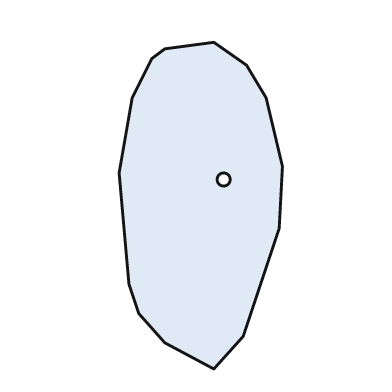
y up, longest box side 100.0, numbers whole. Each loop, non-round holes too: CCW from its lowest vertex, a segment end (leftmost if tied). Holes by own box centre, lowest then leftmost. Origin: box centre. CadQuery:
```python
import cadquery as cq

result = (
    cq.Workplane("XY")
    .moveTo(4.0, -50.0)
    .lineTo(13.0, -40.0)
    .lineTo(24.0, -7.0)
    .lineTo(25.0, 12.0)
    .lineTo(20.0, 33.0)
    .lineTo(14.0, 43.0)
    .lineTo(4.0, 50.0)
    .lineTo(-11.0, 48.0)
    .lineTo(-15.0, 45.0)
    .lineTo(-21.0, 33.0)
    .lineTo(-25.0, 10.0)
    .lineTo(-22.0, -24.0)
    .lineTo(-19.0, -33.0)
    .lineTo(-11.0, -42.0)
    .close()
    .moveTo(7.0, 8.0)
    .circle(2.0)
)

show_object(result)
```